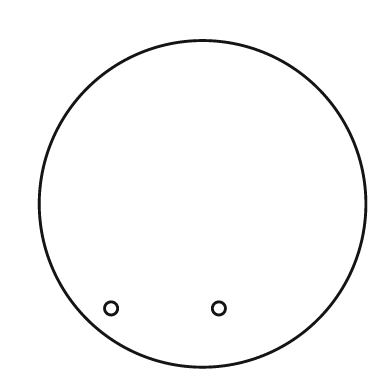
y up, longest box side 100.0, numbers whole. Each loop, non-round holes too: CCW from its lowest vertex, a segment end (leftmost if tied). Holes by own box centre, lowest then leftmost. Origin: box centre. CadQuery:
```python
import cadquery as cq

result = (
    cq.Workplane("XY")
    .moveTo(0.0, 0.0)
    .circle(50.0)
    .moveTo(-28.0, -32.0)
    .circle(2.0)
    .moveTo(5.0, -32.0)
    .circle(2.0)
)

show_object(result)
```